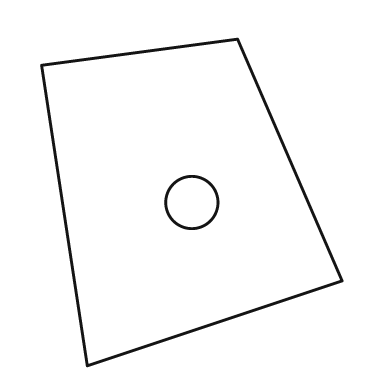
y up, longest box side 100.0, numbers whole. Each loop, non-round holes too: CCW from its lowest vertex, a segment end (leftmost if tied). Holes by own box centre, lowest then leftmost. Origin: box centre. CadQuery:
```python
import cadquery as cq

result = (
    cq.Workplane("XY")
    .moveTo(-32.0, -50.0)
    .lineTo(46.0, -24.0)
    .lineTo(14.0, 50.0)
    .lineTo(-46.0, 42.0)
    .close()
    .moveTo(0.0, 0.0)
    .circle(8.0)
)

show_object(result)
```